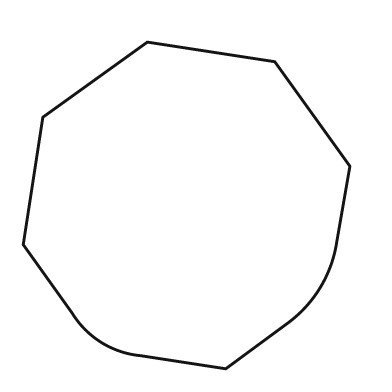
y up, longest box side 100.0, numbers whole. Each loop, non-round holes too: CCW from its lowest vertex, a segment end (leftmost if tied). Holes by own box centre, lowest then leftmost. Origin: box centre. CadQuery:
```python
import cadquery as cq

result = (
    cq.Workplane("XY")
    .moveTo(12.0, -50.0)
    .lineTo(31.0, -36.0)
    .threePointArc((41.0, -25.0), (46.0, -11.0))
    .lineTo(50.0, 12.0)
    .lineTo(27.0, 44.0)
    .lineTo(-12.0, 50.0)
    .lineTo(-44.0, 27.0)
    .lineTo(-50.0, -12.0)
    .lineTo(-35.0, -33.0)
    .threePointArc((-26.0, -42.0), (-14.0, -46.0))
    .close()
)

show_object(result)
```